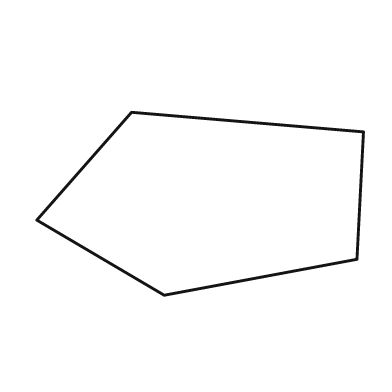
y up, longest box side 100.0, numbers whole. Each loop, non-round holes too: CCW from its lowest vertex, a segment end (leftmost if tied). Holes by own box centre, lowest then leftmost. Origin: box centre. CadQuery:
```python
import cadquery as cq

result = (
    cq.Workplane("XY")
    .moveTo(-11.0, -28.0)
    .lineTo(48.0, -17.0)
    .lineTo(50.0, 22.0)
    .lineTo(-21.0, 28.0)
    .lineTo(-50.0, -5.0)
    .close()
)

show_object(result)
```